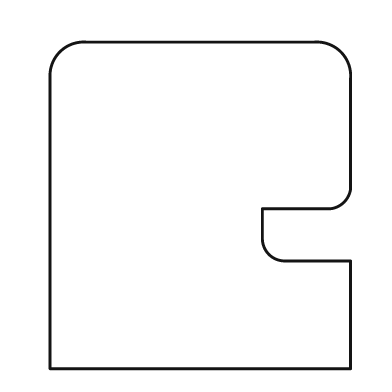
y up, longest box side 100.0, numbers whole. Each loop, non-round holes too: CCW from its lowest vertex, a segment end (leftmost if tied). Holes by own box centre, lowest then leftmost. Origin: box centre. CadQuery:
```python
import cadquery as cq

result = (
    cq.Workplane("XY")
    .moveTo(-46.0, -50.0)
    .lineTo(46.0, -50.0)
    .lineTo(46.0, -17.0)
    .lineTo(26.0, -17.0)
    .threePointArc((21.0, -15.0), (19.0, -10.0))
    .lineTo(19.0, -1.0)
    .lineTo(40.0, -1.0)
    .threePointArc((44.0, 1.0), (46.0, 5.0))
    .lineTo(46.0, 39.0)
    .threePointArc((43.0, 47.0), (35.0, 50.0))
    .lineTo(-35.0, 50.0)
    .threePointArc((-43.0, 47.0), (-46.0, 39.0))
    .close()
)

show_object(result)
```